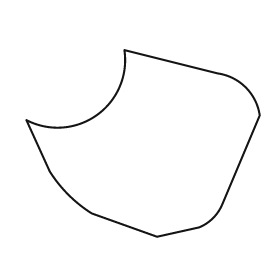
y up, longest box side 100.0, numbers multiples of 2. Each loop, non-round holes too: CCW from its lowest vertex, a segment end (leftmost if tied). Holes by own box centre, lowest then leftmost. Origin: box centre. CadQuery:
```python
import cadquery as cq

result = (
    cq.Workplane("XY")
    .moveTo(6.0, -40.0)
    .lineTo(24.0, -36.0)
    .threePointArc((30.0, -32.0), (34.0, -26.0))
    .lineTo(50.0, 12.0)
    .threePointArc((44.0, 24.0), (32.0, 30.0))
    .lineTo(-8.0, 40.0)
    .threePointArc((-20.0, 12.0), (-50.0, 10.0))
    .lineTo(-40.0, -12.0)
    .threePointArc((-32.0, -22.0), (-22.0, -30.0))
    .close()
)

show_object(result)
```